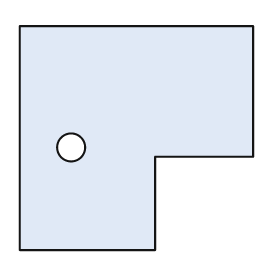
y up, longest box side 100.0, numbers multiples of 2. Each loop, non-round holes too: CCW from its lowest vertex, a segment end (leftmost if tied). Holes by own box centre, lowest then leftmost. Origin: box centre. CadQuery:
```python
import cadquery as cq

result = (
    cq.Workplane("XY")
    .moveTo(-50.0, -48.0)
    .lineTo(8.0, -48.0)
    .lineTo(8.0, -8.0)
    .lineTo(50.0, -8.0)
    .lineTo(50.0, 48.0)
    .lineTo(-50.0, 48.0)
    .close()
    .moveTo(-28.0, -4.0)
    .circle(6.0)
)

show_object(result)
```